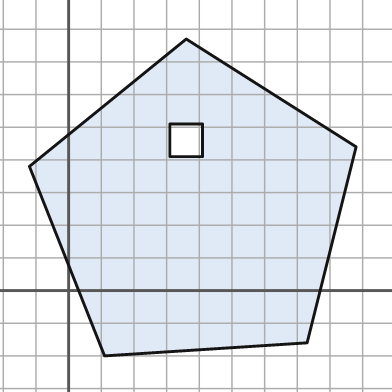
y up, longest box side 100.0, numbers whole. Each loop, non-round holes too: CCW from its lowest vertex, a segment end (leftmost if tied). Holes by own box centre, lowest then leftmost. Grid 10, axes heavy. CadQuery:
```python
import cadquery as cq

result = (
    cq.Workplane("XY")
    .moveTo(11.0, -20.0)
    .lineTo(73.0, -16.0)
    .lineTo(88.0, 44.0)
    .lineTo(36.0, 77.0)
    .lineTo(-12.0, 38.0)
    .close()
    .moveTo(31.0, 41.0)
    .lineTo(41.0, 41.0)
    .lineTo(41.0, 51.0)
    .lineTo(31.0, 51.0)
    .close()
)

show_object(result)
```